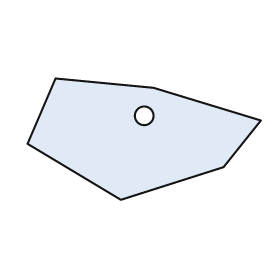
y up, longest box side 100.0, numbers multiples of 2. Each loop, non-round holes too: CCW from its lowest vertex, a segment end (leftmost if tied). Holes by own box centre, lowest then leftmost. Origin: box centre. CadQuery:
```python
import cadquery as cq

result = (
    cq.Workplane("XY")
    .moveTo(-10.0, -26.0)
    .lineTo(34.0, -12.0)
    .lineTo(50.0, 8.0)
    .lineTo(4.0, 22.0)
    .lineTo(-38.0, 26.0)
    .lineTo(-50.0, -2.0)
    .close()
    .moveTo(0.0, 10.0)
    .circle(4.0)
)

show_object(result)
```